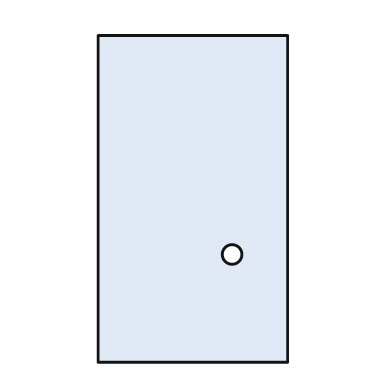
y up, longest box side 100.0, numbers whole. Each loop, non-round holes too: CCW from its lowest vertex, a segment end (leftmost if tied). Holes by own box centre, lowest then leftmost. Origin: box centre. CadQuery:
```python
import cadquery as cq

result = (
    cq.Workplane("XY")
    .moveTo(-29.0, -50.0)
    .lineTo(29.0, -50.0)
    .lineTo(29.0, 50.0)
    .lineTo(-29.0, 50.0)
    .close()
    .moveTo(12.0, -17.0)
    .circle(3.0)
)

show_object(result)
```